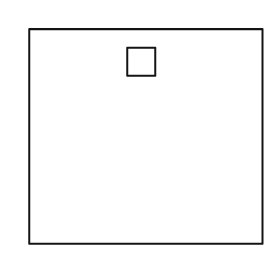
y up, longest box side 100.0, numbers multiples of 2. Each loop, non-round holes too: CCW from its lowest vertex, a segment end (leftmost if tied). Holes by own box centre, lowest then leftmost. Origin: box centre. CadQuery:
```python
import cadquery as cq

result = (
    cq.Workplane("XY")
    .moveTo(-50.0, -46.0)
    .lineTo(50.0, -46.0)
    .lineTo(50.0, 46.0)
    .lineTo(-50.0, 46.0)
    .close()
    .moveTo(-8.0, 26.0)
    .lineTo(4.0, 26.0)
    .lineTo(4.0, 38.0)
    .lineTo(-8.0, 38.0)
    .close()
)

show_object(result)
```